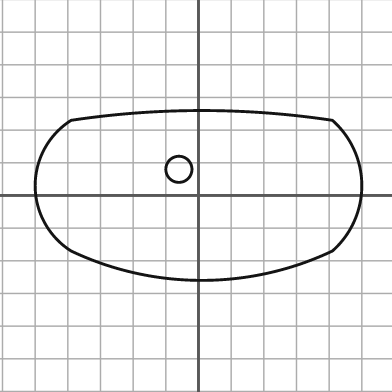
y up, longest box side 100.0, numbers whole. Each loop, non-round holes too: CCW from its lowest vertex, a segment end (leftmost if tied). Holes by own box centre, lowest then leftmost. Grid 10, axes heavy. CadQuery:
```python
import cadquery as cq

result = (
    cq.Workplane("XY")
    .moveTo(-39.0, -17.0)
    .threePointArc((1.0, -26.0), (41.0, -17.0))
    .threePointArc((50.0, 3.0), (41.0, 23.0))
    .threePointArc((1.0, 26.0), (-39.0, 23.0))
    .threePointArc((-50.0, 3.0), (-39.0, -17.0))
    .close()
    .moveTo(-6.0, 8.0)
    .circle(4.0)
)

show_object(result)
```